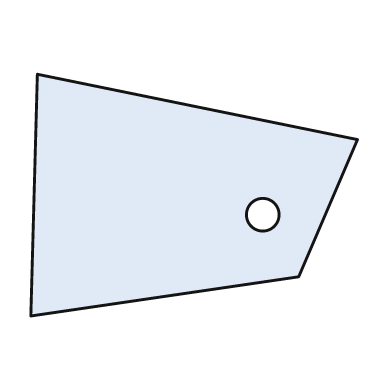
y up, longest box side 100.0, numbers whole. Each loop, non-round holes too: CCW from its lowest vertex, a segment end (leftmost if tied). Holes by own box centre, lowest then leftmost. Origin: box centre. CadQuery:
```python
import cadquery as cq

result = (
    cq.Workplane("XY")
    .moveTo(-50.0, -37.0)
    .lineTo(32.0, -25.0)
    .lineTo(50.0, 17.0)
    .lineTo(-48.0, 37.0)
    .close()
    .moveTo(21.0, -6.0)
    .circle(5.0)
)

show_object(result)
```